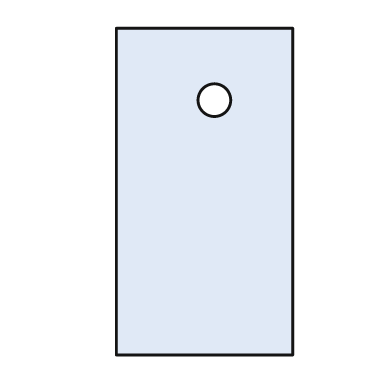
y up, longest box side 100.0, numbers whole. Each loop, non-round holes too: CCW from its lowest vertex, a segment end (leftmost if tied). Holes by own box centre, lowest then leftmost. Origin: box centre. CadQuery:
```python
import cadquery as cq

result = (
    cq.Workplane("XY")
    .moveTo(-27.0, -50.0)
    .lineTo(27.0, -50.0)
    .lineTo(27.0, 50.0)
    .lineTo(-27.0, 50.0)
    .close()
    .moveTo(3.0, 28.0)
    .circle(5.0)
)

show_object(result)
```